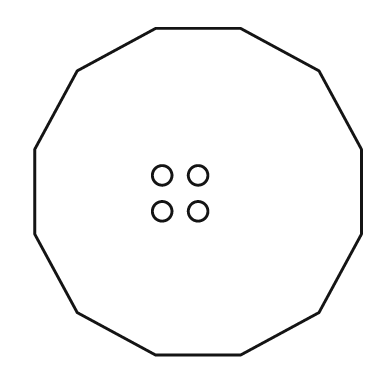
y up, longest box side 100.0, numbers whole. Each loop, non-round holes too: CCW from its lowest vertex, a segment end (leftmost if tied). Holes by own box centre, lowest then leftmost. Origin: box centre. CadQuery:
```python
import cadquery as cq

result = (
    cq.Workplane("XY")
    .moveTo(-13.0, -50.0)
    .lineTo(13.0, -50.0)
    .lineTo(37.0, -37.0)
    .lineTo(50.0, -13.0)
    .lineTo(50.0, 13.0)
    .lineTo(37.0, 37.0)
    .lineTo(13.0, 50.0)
    .lineTo(-13.0, 50.0)
    .lineTo(-37.0, 37.0)
    .lineTo(-50.0, 13.0)
    .lineTo(-50.0, -13.0)
    .lineTo(-37.0, -37.0)
    .close()
    .moveTo(-11.0, -6.0)
    .circle(3.0)
    .moveTo(0.0, -6.0)
    .circle(3.0)
    .moveTo(-11.0, 5.0)
    .circle(3.0)
    .moveTo(0.0, 5.0)
    .circle(3.0)
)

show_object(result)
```